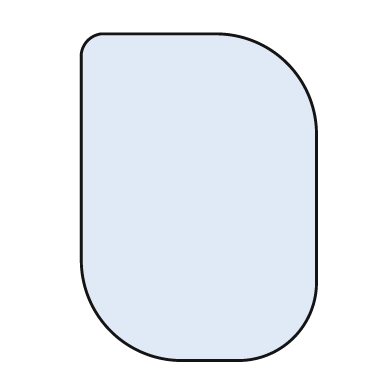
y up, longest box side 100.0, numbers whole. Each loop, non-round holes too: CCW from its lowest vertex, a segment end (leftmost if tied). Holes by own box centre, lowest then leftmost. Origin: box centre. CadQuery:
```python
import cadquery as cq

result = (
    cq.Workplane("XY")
    .moveTo(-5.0, -50.0)
    .lineTo(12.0, -50.0)
    .threePointArc((29.0, -43.0), (36.0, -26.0))
    .lineTo(36.0, 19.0)
    .threePointArc((27.0, 41.0), (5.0, 50.0))
    .lineTo(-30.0, 50.0)
    .threePointArc((-34.0, 48.0), (-36.0, 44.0))
    .lineTo(-36.0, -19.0)
    .threePointArc((-27.0, -41.0), (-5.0, -50.0))
    .close()
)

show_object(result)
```